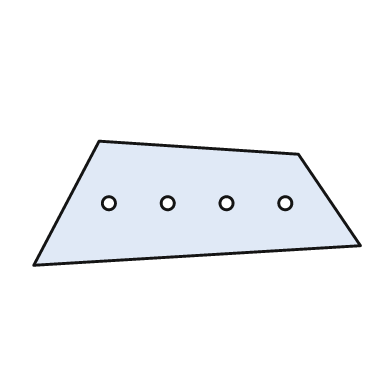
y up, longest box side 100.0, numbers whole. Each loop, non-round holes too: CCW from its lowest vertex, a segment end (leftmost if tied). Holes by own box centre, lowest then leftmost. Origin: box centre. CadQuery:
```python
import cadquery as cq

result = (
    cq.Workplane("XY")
    .moveTo(-50.0, -19.0)
    .lineTo(50.0, -13.0)
    .lineTo(31.0, 15.0)
    .lineTo(-30.0, 19.0)
    .close()
    .moveTo(-27.0, 0.0)
    .circle(2.0)
    .moveTo(-9.0, 0.0)
    .circle(2.0)
    .moveTo(9.0, 0.0)
    .circle(2.0)
    .moveTo(27.0, 0.0)
    .circle(2.0)
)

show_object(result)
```